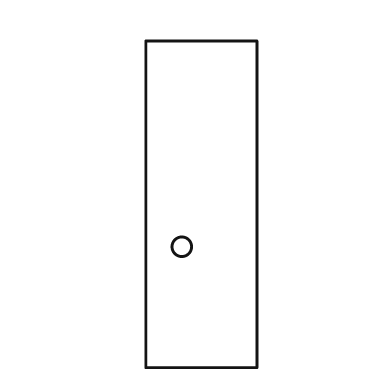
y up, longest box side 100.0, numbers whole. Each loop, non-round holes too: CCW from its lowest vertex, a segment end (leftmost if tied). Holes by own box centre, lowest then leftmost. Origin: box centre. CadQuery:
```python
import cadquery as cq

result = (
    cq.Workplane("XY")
    .moveTo(-17.0, -50.0)
    .lineTo(17.0, -50.0)
    .lineTo(17.0, 50.0)
    .lineTo(-17.0, 50.0)
    .close()
    .moveTo(-6.0, -13.0)
    .circle(3.0)
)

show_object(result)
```